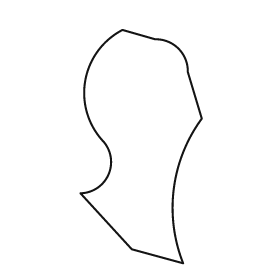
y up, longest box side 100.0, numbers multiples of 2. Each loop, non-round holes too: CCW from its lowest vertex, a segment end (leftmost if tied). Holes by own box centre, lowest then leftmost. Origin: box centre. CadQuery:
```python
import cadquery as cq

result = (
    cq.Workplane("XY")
    .moveTo(18.0, -50.0)
    .threePointArc((14.0, -18.0), (26.0, 12.0))
    .lineTo(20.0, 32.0)
    .threePointArc((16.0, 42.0), (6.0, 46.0))
    .lineTo(-8.0, 50.0)
    .threePointArc((-24.0, 28.0), (-16.0, 2.0))
    .threePointArc((-14.0, -12.0), (-26.0, -20.0))
    .lineTo(-4.0, -44.0)
    .close()
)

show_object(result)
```